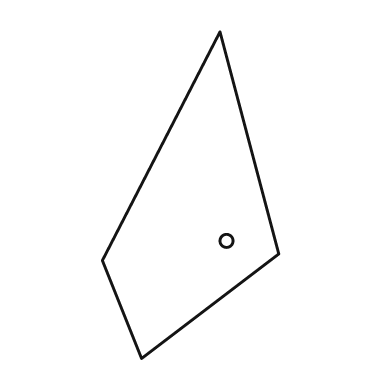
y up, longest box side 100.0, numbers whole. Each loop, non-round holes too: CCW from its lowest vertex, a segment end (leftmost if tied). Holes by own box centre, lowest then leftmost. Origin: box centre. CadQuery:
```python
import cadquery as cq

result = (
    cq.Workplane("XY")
    .moveTo(-15.0, -50.0)
    .lineTo(27.0, -18.0)
    .lineTo(9.0, 50.0)
    .lineTo(-27.0, -20.0)
    .close()
    .moveTo(11.0, -14.0)
    .circle(2.0)
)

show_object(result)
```